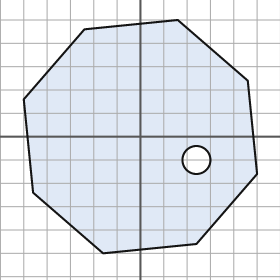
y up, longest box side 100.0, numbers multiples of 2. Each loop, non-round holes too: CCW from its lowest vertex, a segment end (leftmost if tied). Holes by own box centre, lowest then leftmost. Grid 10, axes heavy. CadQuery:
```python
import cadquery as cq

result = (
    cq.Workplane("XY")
    .moveTo(-16.0, -50.0)
    .lineTo(24.0, -46.0)
    .lineTo(50.0, -16.0)
    .lineTo(46.0, 24.0)
    .lineTo(16.0, 50.0)
    .lineTo(-24.0, 46.0)
    .lineTo(-50.0, 16.0)
    .lineTo(-46.0, -24.0)
    .close()
    .moveTo(24.0, -10.0)
    .circle(6.0)
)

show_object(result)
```